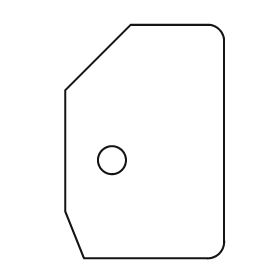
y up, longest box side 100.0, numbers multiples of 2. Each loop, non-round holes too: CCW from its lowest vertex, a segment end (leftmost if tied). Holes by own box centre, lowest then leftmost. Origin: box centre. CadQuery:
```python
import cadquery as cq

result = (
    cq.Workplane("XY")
    .moveTo(-26.0, -50.0)
    .lineTo(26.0, -50.0)
    .threePointArc((32.0, -48.0), (34.0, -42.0))
    .lineTo(34.0, 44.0)
    .threePointArc((32.0, 48.0), (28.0, 50.0))
    .lineTo(-6.0, 50.0)
    .lineTo(-34.0, 22.0)
    .lineTo(-34.0, -30.0)
    .close()
    .moveTo(-14.0, -8.0)
    .circle(6.0)
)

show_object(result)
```